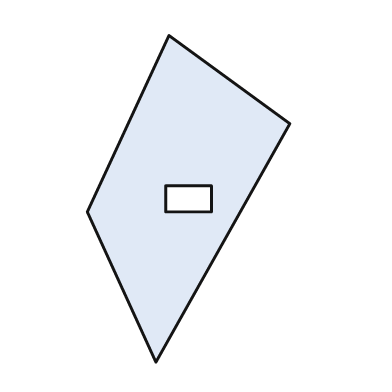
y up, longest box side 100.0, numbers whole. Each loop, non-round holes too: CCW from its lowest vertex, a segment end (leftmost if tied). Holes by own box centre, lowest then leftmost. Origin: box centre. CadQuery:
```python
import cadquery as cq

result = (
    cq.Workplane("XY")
    .moveTo(-10.0, -50.0)
    .lineTo(31.0, 23.0)
    .lineTo(-6.0, 50.0)
    .lineTo(-31.0, -4.0)
    .close()
    .moveTo(-7.0, -4.0)
    .lineTo(7.0, -4.0)
    .lineTo(7.0, 4.0)
    .lineTo(-7.0, 4.0)
    .close()
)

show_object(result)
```